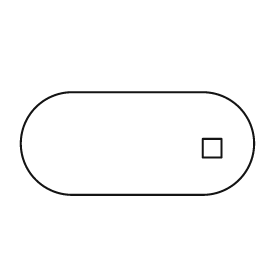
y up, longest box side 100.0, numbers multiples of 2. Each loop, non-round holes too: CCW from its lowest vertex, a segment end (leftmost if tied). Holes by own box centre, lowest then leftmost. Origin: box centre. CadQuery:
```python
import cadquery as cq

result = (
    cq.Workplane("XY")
    .moveTo(-28.0, -22.0)
    .lineTo(28.0, -22.0)
    .threePointArc((50.0, 0.0), (28.0, 22.0))
    .lineTo(-28.0, 22.0)
    .threePointArc((-50.0, 0.0), (-28.0, -22.0))
    .close()
    .moveTo(28.0, -6.0)
    .lineTo(36.0, -6.0)
    .lineTo(36.0, 2.0)
    .lineTo(28.0, 2.0)
    .close()
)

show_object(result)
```